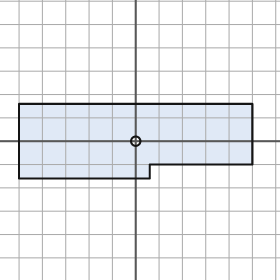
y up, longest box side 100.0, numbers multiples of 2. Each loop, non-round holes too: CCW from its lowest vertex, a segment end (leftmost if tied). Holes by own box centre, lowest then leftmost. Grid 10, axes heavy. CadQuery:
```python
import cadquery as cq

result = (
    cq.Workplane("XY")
    .moveTo(-50.0, -16.0)
    .lineTo(6.0, -16.0)
    .lineTo(6.0, -10.0)
    .lineTo(50.0, -10.0)
    .lineTo(50.0, 16.0)
    .lineTo(-50.0, 16.0)
    .close()
    .moveTo(0.0, 0.0)
    .circle(2.0)
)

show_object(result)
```